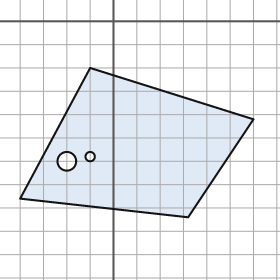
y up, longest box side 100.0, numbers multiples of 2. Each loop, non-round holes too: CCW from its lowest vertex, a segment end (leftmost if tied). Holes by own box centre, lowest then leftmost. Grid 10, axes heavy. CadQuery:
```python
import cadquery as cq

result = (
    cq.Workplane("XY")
    .moveTo(32.0, -84.0)
    .lineTo(60.0, -42.0)
    .lineTo(-10.0, -20.0)
    .lineTo(-40.0, -76.0)
    .close()
    .moveTo(-20.0, -60.0)
    .circle(4.0)
    .moveTo(-10.0, -58.0)
    .circle(2.0)
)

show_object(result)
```